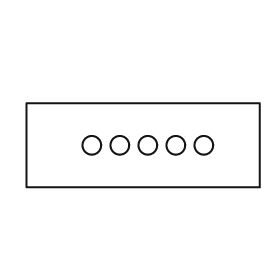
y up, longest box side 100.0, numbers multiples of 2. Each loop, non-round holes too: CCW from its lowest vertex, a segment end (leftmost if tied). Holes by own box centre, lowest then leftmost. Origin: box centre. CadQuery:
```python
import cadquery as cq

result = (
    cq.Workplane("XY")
    .moveTo(-50.0, -18.0)
    .lineTo(50.0, -18.0)
    .lineTo(50.0, 18.0)
    .lineTo(-50.0, 18.0)
    .close()
    .moveTo(-22.0, 0.0)
    .circle(4.0)
    .moveTo(-10.0, 0.0)
    .circle(4.0)
    .moveTo(2.0, 0.0)
    .circle(4.0)
    .moveTo(14.0, 0.0)
    .circle(4.0)
    .moveTo(26.0, 0.0)
    .circle(4.0)
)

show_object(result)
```